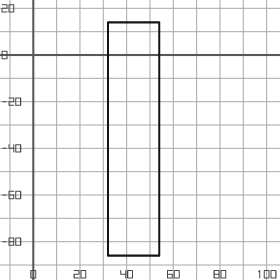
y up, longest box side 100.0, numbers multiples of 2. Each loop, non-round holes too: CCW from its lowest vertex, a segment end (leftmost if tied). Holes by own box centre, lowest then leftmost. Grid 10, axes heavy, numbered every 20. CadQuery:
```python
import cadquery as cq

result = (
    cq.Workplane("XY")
    .moveTo(32.0, -86.0)
    .lineTo(54.0, -86.0)
    .lineTo(54.0, 14.0)
    .lineTo(32.0, 14.0)
    .close()
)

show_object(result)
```